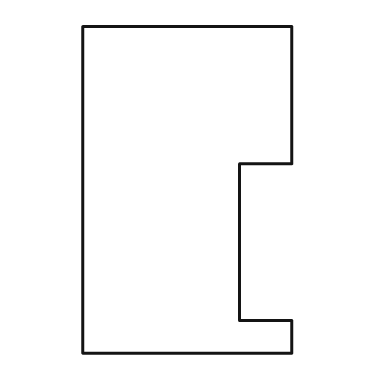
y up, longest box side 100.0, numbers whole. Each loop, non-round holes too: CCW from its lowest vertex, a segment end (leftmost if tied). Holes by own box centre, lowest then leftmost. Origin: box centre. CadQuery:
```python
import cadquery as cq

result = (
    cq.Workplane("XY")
    .moveTo(-32.0, -50.0)
    .lineTo(32.0, -50.0)
    .lineTo(32.0, -40.0)
    .lineTo(16.0, -40.0)
    .lineTo(16.0, 8.0)
    .lineTo(32.0, 8.0)
    .lineTo(32.0, 50.0)
    .lineTo(-32.0, 50.0)
    .close()
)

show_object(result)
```